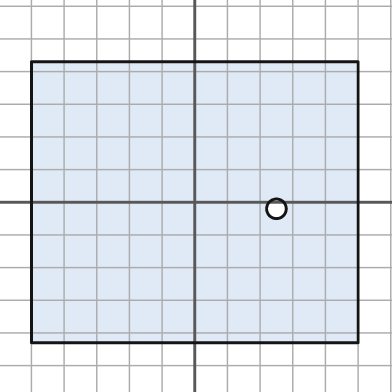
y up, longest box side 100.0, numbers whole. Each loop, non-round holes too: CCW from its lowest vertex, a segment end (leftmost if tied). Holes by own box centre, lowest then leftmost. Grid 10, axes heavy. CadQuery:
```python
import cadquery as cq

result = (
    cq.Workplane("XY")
    .moveTo(-50.0, -43.0)
    .lineTo(50.0, -43.0)
    .lineTo(50.0, 43.0)
    .lineTo(-50.0, 43.0)
    .close()
    .moveTo(25.0, -2.0)
    .circle(3.0)
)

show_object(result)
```